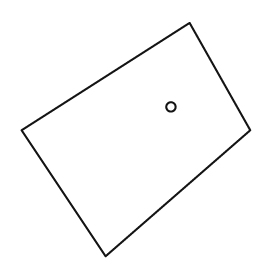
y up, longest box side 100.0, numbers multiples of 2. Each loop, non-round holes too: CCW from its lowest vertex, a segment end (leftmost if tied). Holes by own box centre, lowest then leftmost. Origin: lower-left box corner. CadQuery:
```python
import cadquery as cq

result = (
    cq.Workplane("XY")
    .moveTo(36.0, 0.0)
    .lineTo(98.0, 54.0)
    .lineTo(72.0, 100.0)
    .lineTo(0.0, 54.0)
    .close()
    .moveTo(64.0, 64.0)
    .circle(2.0)
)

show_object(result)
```